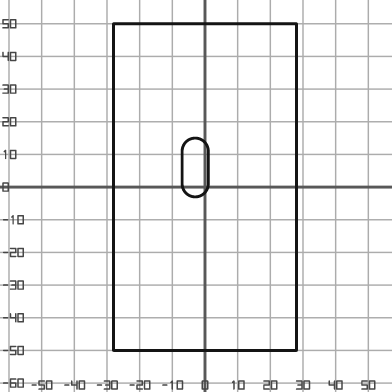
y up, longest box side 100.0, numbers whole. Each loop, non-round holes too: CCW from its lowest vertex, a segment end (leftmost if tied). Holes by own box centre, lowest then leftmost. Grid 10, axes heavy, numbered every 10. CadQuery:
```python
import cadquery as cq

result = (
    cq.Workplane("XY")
    .moveTo(-28.0, -50.0)
    .lineTo(28.0, -50.0)
    .lineTo(28.0, 50.0)
    .lineTo(-28.0, 50.0)
    .close()
    .moveTo(-7.0, 1.0)
    .threePointArc((-3.0, -3.0), (1.0, 1.0))
    .lineTo(1.0, 11.0)
    .threePointArc((-3.0, 15.0), (-7.0, 11.0))
    .close()
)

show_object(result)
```